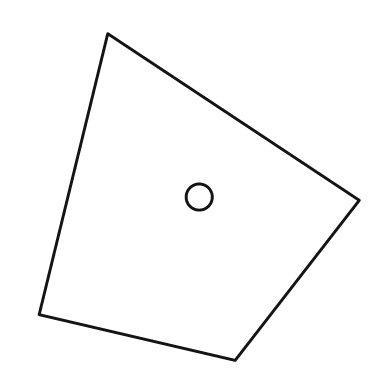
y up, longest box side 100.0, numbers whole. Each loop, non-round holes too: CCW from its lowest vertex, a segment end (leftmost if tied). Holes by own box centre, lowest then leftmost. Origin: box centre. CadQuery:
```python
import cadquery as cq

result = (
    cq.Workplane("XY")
    .moveTo(11.0, -50.0)
    .lineTo(49.0, -1.0)
    .lineTo(-28.0, 50.0)
    .lineTo(-49.0, -36.0)
    .close()
    .moveTo(0.0, 0.0)
    .circle(4.0)
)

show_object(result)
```